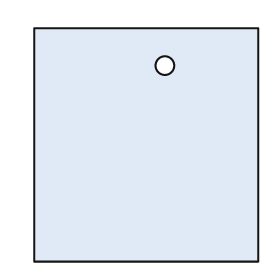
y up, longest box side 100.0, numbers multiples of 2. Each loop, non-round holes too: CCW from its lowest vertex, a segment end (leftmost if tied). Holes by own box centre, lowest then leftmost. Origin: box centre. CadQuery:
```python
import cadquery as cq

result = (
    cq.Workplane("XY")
    .moveTo(-48.0, -50.0)
    .lineTo(48.0, -50.0)
    .lineTo(48.0, 50.0)
    .lineTo(-48.0, 50.0)
    .close()
    .moveTo(8.0, 34.0)
    .circle(4.0)
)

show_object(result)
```